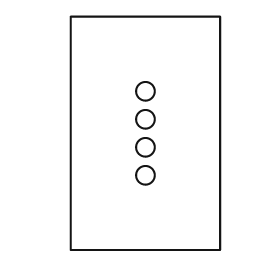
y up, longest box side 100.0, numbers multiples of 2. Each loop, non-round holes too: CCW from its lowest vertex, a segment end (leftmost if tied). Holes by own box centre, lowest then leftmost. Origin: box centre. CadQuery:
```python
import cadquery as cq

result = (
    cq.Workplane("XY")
    .moveTo(-32.0, -50.0)
    .lineTo(32.0, -50.0)
    .lineTo(32.0, 50.0)
    .lineTo(-32.0, 50.0)
    .close()
    .moveTo(0.0, -18.0)
    .circle(4.0)
    .moveTo(0.0, -6.0)
    .circle(4.0)
    .moveTo(0.0, 6.0)
    .circle(4.0)
    .moveTo(0.0, 18.0)
    .circle(4.0)
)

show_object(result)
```